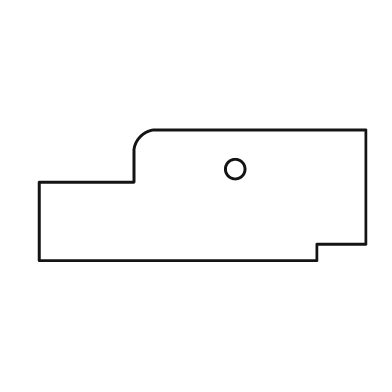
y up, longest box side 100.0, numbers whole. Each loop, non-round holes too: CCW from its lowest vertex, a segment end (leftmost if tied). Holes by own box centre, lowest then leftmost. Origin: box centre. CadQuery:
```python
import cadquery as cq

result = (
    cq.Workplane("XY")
    .moveTo(-50.0, -20.0)
    .lineTo(35.0, -20.0)
    .lineTo(35.0, -15.0)
    .lineTo(50.0, -15.0)
    .lineTo(50.0, 20.0)
    .lineTo(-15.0, 20.0)
    .threePointArc((-19.0, 18.0), (-21.0, 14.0))
    .lineTo(-21.0, 4.0)
    .lineTo(-50.0, 4.0)
    .close()
    .moveTo(10.0, 8.0)
    .circle(3.0)
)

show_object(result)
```